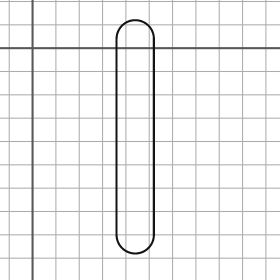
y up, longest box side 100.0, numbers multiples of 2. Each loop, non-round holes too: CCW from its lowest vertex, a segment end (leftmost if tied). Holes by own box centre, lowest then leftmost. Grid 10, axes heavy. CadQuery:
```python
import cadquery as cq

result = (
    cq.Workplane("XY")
    .moveTo(36.0, -80.0)
    .threePointArc((44.0, -88.0), (52.0, -80.0))
    .lineTo(52.0, 4.0)
    .threePointArc((44.0, 12.0), (36.0, 4.0))
    .close()
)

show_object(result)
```